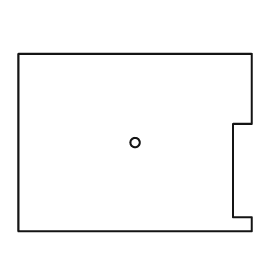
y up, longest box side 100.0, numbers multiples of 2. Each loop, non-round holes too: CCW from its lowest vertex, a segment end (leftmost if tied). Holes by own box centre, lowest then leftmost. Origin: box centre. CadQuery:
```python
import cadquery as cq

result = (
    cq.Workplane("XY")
    .moveTo(-50.0, -38.0)
    .lineTo(50.0, -38.0)
    .lineTo(50.0, -32.0)
    .lineTo(42.0, -32.0)
    .lineTo(42.0, 8.0)
    .lineTo(50.0, 8.0)
    .lineTo(50.0, 38.0)
    .lineTo(-50.0, 38.0)
    .close()
    .moveTo(0.0, 0.0)
    .circle(2.0)
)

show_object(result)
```